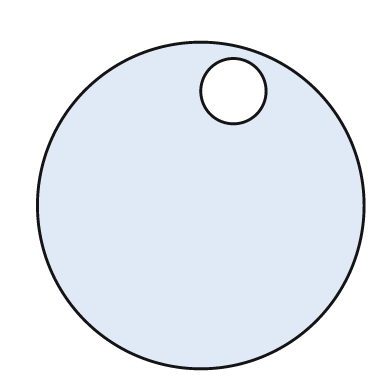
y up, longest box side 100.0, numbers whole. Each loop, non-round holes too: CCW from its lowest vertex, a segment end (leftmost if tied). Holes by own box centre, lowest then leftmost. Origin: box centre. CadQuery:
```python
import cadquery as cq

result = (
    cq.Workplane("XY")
    .moveTo(0.0, 0.0)
    .circle(50.0)
    .moveTo(10.0, 35.0)
    .circle(10.0)
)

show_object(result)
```